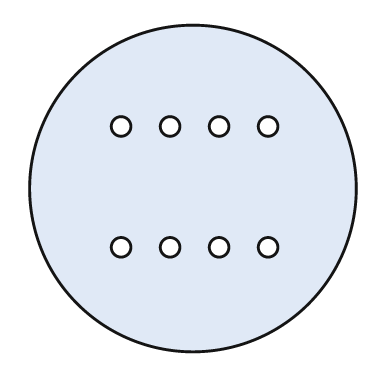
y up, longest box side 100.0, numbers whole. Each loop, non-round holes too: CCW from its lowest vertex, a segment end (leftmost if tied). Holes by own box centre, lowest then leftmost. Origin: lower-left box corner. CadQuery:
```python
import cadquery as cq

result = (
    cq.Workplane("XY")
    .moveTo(50.0, 50.0)
    .circle(50.0)
    .moveTo(28.0, 32.0)
    .circle(3.0)
    .moveTo(43.0, 32.0)
    .circle(3.0)
    .moveTo(58.0, 32.0)
    .circle(3.0)
    .moveTo(73.0, 32.0)
    .circle(3.0)
    .moveTo(28.0, 69.0)
    .circle(3.0)
    .moveTo(43.0, 69.0)
    .circle(3.0)
    .moveTo(58.0, 69.0)
    .circle(3.0)
    .moveTo(73.0, 69.0)
    .circle(3.0)
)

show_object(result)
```